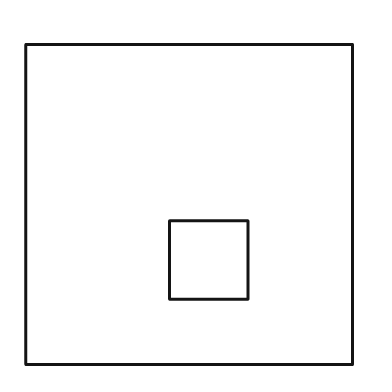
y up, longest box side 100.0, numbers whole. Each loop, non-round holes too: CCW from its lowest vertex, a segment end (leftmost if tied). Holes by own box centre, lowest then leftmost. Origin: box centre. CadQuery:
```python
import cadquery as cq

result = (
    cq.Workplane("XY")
    .moveTo(-50.0, -49.0)
    .lineTo(50.0, -49.0)
    .lineTo(50.0, 49.0)
    .lineTo(-50.0, 49.0)
    .close()
    .moveTo(-6.0, -29.0)
    .lineTo(18.0, -29.0)
    .lineTo(18.0, -5.0)
    .lineTo(-6.0, -5.0)
    .close()
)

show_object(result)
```